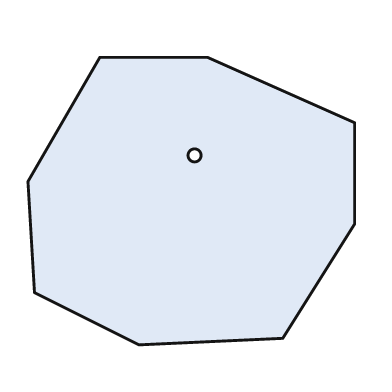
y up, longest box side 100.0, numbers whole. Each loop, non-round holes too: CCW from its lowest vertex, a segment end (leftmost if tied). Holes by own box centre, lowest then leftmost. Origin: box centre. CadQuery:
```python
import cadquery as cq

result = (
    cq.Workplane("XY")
    .moveTo(-16.0, -44.0)
    .lineTo(28.0, -42.0)
    .lineTo(50.0, -7.0)
    .lineTo(50.0, 24.0)
    .lineTo(5.0, 44.0)
    .lineTo(-28.0, 44.0)
    .lineTo(-50.0, 6.0)
    .lineTo(-48.0, -28.0)
    .close()
    .moveTo(1.0, 14.0)
    .circle(2.0)
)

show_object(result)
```